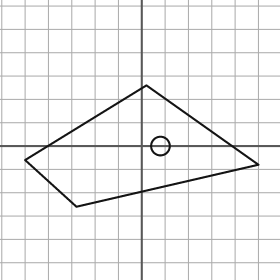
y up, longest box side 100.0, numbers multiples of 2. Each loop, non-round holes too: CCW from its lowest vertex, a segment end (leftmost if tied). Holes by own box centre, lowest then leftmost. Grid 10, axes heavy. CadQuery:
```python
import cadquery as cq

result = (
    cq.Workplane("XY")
    .moveTo(-28.0, -26.0)
    .lineTo(50.0, -8.0)
    .lineTo(2.0, 26.0)
    .lineTo(-50.0, -6.0)
    .close()
    .moveTo(8.0, 0.0)
    .circle(4.0)
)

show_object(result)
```